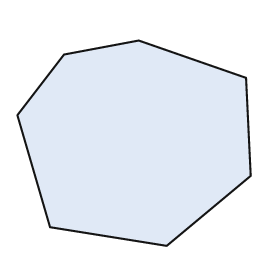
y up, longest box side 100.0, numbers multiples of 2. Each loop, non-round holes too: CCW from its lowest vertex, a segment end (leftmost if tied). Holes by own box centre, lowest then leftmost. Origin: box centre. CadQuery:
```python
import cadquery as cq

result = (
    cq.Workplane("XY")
    .moveTo(14.0, -44.0)
    .lineTo(50.0, -14.0)
    .lineTo(48.0, 28.0)
    .lineTo(2.0, 44.0)
    .lineTo(-30.0, 38.0)
    .lineTo(-50.0, 12.0)
    .lineTo(-36.0, -36.0)
    .close()
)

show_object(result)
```